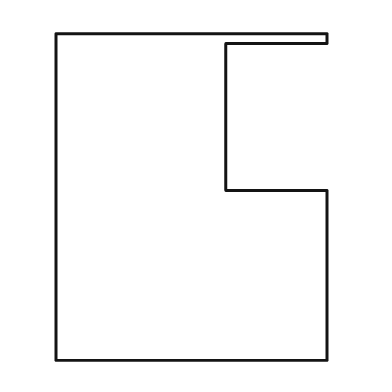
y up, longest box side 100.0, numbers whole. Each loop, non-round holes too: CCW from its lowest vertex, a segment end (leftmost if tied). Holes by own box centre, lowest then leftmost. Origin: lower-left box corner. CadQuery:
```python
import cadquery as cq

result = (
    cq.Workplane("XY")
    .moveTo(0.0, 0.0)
    .lineTo(83.0, 0.0)
    .lineTo(83.0, 52.0)
    .lineTo(52.0, 52.0)
    .lineTo(52.0, 97.0)
    .lineTo(83.0, 97.0)
    .lineTo(83.0, 100.0)
    .lineTo(0.0, 100.0)
    .close()
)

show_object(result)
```